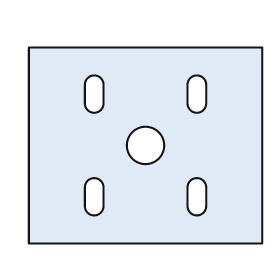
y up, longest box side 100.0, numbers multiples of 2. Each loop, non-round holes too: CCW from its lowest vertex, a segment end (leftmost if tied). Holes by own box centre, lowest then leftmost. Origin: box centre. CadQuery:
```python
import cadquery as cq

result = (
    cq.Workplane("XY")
    .moveTo(-50.0, -42.0)
    .lineTo(50.0, -42.0)
    .lineTo(50.0, 42.0)
    .lineTo(-50.0, 42.0)
    .close()
    .moveTo(-26.0, -26.0)
    .threePointArc((-22.0, -30.0), (-18.0, -26.0))
    .lineTo(-18.0, -18.0)
    .threePointArc((-22.0, -14.0), (-26.0, -18.0))
    .close()
    .moveTo(18.0, -26.0)
    .threePointArc((22.0, -30.0), (26.0, -26.0))
    .lineTo(26.0, -18.0)
    .threePointArc((22.0, -14.0), (18.0, -18.0))
    .close()
    .moveTo(0.0, 0.0)
    .circle(8.0)
    .moveTo(-26.0, 18.0)
    .threePointArc((-22.0, 14.0), (-18.0, 18.0))
    .lineTo(-18.0, 26.0)
    .threePointArc((-22.0, 30.0), (-26.0, 26.0))
    .close()
    .moveTo(18.0, 18.0)
    .threePointArc((22.0, 14.0), (26.0, 18.0))
    .lineTo(26.0, 26.0)
    .threePointArc((22.0, 30.0), (18.0, 26.0))
    .close()
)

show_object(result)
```